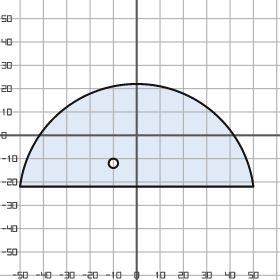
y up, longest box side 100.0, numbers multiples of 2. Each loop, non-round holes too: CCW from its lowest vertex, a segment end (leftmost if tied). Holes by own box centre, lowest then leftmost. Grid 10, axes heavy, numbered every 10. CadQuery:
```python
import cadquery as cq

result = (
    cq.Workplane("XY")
    .moveTo(-50.0, -22.0)
    .lineTo(50.0, -22.0)
    .threePointArc((0.0, 22.0), (-50.0, -22.0))
    .close()
    .moveTo(-10.0, -12.0)
    .circle(2.0)
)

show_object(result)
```